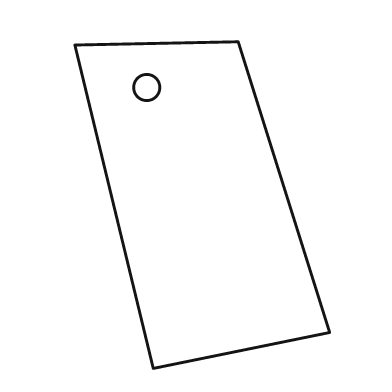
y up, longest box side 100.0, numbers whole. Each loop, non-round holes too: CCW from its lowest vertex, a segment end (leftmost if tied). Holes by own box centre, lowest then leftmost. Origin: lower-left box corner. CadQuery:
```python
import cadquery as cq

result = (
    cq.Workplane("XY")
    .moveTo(24.0, 0.0)
    .lineTo(78.0, 11.0)
    .lineTo(50.0, 100.0)
    .lineTo(0.0, 99.0)
    .close()
    .moveTo(22.0, 86.0)
    .circle(4.0)
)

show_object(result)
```